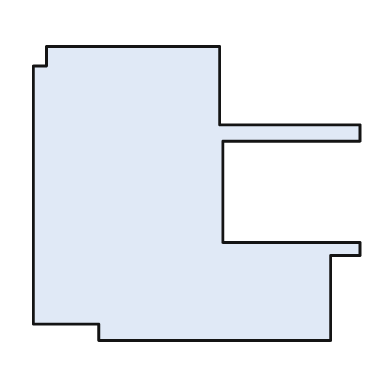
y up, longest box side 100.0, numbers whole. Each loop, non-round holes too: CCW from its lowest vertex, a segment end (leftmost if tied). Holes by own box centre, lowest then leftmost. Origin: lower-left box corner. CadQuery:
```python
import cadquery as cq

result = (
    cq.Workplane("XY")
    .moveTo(20.0, 0.0)
    .lineTo(91.0, 0.0)
    .lineTo(91.0, 26.0)
    .lineTo(100.0, 26.0)
    .lineTo(100.0, 30.0)
    .lineTo(58.0, 30.0)
    .lineTo(58.0, 61.0)
    .lineTo(100.0, 61.0)
    .lineTo(100.0, 66.0)
    .lineTo(57.0, 66.0)
    .lineTo(57.0, 90.0)
    .lineTo(4.0, 90.0)
    .lineTo(4.0, 84.0)
    .lineTo(0.0, 84.0)
    .lineTo(0.0, 5.0)
    .lineTo(20.0, 5.0)
    .close()
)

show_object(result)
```